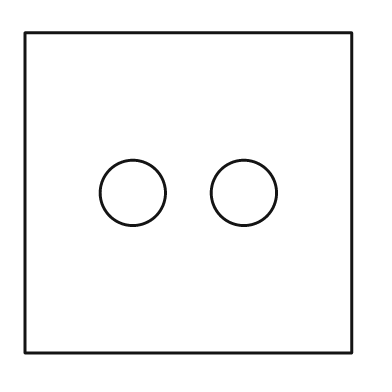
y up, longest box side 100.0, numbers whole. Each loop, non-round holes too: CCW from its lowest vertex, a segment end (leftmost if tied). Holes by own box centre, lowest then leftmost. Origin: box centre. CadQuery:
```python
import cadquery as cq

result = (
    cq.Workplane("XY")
    .moveTo(-50.0, -49.0)
    .lineTo(50.0, -49.0)
    .lineTo(50.0, 49.0)
    .lineTo(-50.0, 49.0)
    .close()
    .moveTo(-17.0, 0.0)
    .circle(10.0)
    .moveTo(17.0, 0.0)
    .circle(10.0)
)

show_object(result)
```